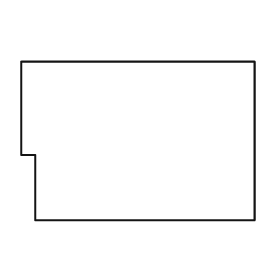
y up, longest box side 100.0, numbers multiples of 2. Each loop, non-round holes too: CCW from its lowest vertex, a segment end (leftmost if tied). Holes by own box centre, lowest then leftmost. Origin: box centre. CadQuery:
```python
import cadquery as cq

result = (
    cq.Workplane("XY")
    .moveTo(-44.0, -34.0)
    .lineTo(50.0, -34.0)
    .lineTo(50.0, 34.0)
    .lineTo(-50.0, 34.0)
    .lineTo(-50.0, -6.0)
    .lineTo(-44.0, -6.0)
    .close()
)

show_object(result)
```